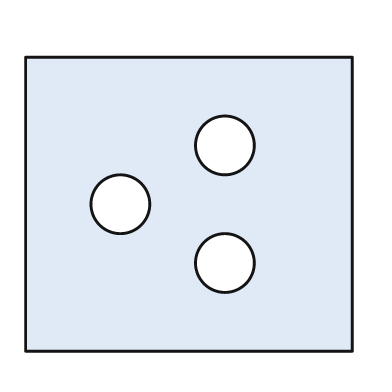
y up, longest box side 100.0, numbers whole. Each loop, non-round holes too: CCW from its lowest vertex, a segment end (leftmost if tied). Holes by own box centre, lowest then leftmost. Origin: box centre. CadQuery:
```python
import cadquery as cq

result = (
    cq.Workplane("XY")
    .moveTo(-50.0, -45.0)
    .lineTo(50.0, -45.0)
    .lineTo(50.0, 45.0)
    .lineTo(-50.0, 45.0)
    .close()
    .moveTo(11.0, -18.0)
    .circle(9.0)
    .moveTo(-21.0, 0.0)
    .circle(9.0)
    .moveTo(11.0, 18.0)
    .circle(9.0)
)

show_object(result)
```